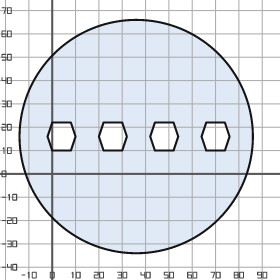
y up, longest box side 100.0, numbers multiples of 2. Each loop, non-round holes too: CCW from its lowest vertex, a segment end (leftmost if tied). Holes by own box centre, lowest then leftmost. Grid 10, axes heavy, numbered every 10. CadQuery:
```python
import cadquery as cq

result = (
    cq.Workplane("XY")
    .moveTo(36.0, 16.0)
    .circle(50.0)
    .moveTo(0.0, 10.0)
    .lineTo(8.0, 10.0)
    .lineTo(10.0, 16.0)
    .lineTo(8.0, 22.0)
    .lineTo(0.0, 22.0)
    .lineTo(-2.0, 16.0)
    .close()
    .moveTo(22.0, 10.0)
    .lineTo(30.0, 10.0)
    .lineTo(32.0, 16.0)
    .lineTo(30.0, 22.0)
    .lineTo(22.0, 22.0)
    .lineTo(20.0, 16.0)
    .close()
    .moveTo(44.0, 10.0)
    .lineTo(52.0, 10.0)
    .lineTo(54.0, 16.0)
    .lineTo(52.0, 22.0)
    .lineTo(44.0, 22.0)
    .lineTo(42.0, 16.0)
    .close()
    .moveTo(66.0, 10.0)
    .lineTo(74.0, 10.0)
    .lineTo(76.0, 16.0)
    .lineTo(74.0, 22.0)
    .lineTo(66.0, 22.0)
    .lineTo(64.0, 16.0)
    .close()
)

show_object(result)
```